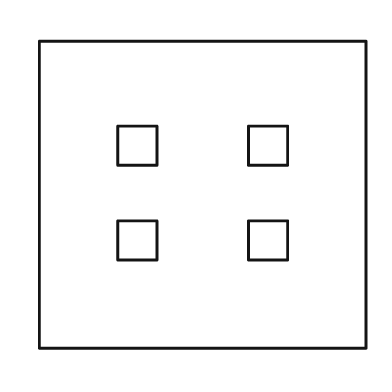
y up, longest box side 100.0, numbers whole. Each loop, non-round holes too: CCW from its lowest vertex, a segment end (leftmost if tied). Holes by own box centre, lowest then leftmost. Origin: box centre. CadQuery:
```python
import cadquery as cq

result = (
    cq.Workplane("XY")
    .moveTo(-50.0, -47.0)
    .lineTo(50.0, -47.0)
    .lineTo(50.0, 47.0)
    .lineTo(-50.0, 47.0)
    .close()
    .moveTo(-26.0, -20.0)
    .lineTo(-14.0, -20.0)
    .lineTo(-14.0, -8.0)
    .lineTo(-26.0, -8.0)
    .close()
    .moveTo(14.0, -20.0)
    .lineTo(26.0, -20.0)
    .lineTo(26.0, -8.0)
    .lineTo(14.0, -8.0)
    .close()
    .moveTo(-26.0, 9.0)
    .lineTo(-14.0, 9.0)
    .lineTo(-14.0, 21.0)
    .lineTo(-26.0, 21.0)
    .close()
    .moveTo(14.0, 9.0)
    .lineTo(26.0, 9.0)
    .lineTo(26.0, 21.0)
    .lineTo(14.0, 21.0)
    .close()
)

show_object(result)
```